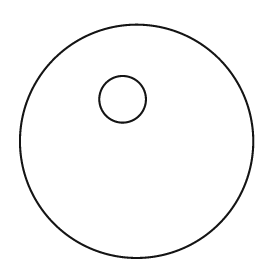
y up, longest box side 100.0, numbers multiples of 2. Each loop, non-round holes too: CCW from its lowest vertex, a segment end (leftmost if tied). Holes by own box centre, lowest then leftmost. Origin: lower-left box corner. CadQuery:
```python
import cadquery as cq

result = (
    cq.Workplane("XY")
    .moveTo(50.0, 50.0)
    .circle(50.0)
    .moveTo(44.0, 68.0)
    .circle(10.0)
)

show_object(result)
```